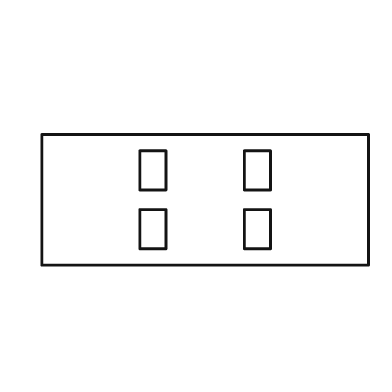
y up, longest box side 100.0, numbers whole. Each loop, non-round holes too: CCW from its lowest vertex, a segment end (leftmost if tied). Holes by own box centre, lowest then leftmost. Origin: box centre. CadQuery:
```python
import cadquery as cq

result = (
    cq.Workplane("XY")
    .moveTo(-50.0, -20.0)
    .lineTo(50.0, -20.0)
    .lineTo(50.0, 20.0)
    .lineTo(-50.0, 20.0)
    .close()
    .moveTo(-20.0, -15.0)
    .lineTo(-12.0, -15.0)
    .lineTo(-12.0, -3.0)
    .lineTo(-20.0, -3.0)
    .close()
    .moveTo(12.0, -15.0)
    .lineTo(20.0, -15.0)
    .lineTo(20.0, -3.0)
    .lineTo(12.0, -3.0)
    .close()
    .moveTo(-20.0, 3.0)
    .lineTo(-12.0, 3.0)
    .lineTo(-12.0, 15.0)
    .lineTo(-20.0, 15.0)
    .close()
    .moveTo(12.0, 3.0)
    .lineTo(20.0, 3.0)
    .lineTo(20.0, 15.0)
    .lineTo(12.0, 15.0)
    .close()
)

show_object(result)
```